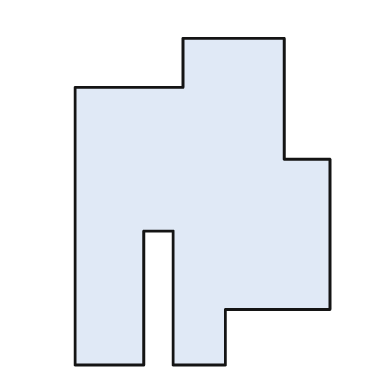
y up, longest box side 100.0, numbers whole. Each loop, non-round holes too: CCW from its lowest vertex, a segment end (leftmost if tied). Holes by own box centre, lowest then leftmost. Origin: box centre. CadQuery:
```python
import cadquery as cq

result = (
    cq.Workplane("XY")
    .moveTo(-39.0, -50.0)
    .lineTo(-18.0, -50.0)
    .lineTo(-18.0, -9.0)
    .lineTo(-9.0, -9.0)
    .lineTo(-9.0, -50.0)
    .lineTo(7.0, -50.0)
    .lineTo(7.0, -33.0)
    .lineTo(39.0, -33.0)
    .lineTo(39.0, 13.0)
    .lineTo(25.0, 13.0)
    .lineTo(25.0, 50.0)
    .lineTo(-6.0, 50.0)
    .lineTo(-6.0, 35.0)
    .lineTo(-39.0, 35.0)
    .close()
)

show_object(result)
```